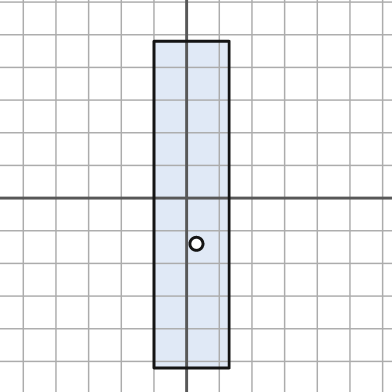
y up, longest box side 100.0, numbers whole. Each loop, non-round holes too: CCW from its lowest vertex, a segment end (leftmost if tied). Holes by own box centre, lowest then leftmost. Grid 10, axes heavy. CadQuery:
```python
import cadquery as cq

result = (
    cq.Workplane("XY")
    .moveTo(-10.0, -52.0)
    .lineTo(13.0, -52.0)
    .lineTo(13.0, 48.0)
    .lineTo(-10.0, 48.0)
    .close()
    .moveTo(3.0, -14.0)
    .circle(2.0)
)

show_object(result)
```